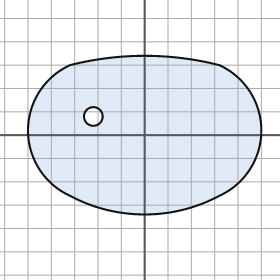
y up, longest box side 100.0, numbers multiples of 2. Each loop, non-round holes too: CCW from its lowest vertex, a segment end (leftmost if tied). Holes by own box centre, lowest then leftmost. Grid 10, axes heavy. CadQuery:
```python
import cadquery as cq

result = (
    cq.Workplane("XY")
    .moveTo(-32.0, -26.0)
    .threePointArc((0.0, -34.0), (32.0, -26.0))
    .threePointArc((50.0, 2.0), (32.0, 30.0))
    .threePointArc((0.0, 34.0), (-32.0, 30.0))
    .threePointArc((-50.0, 2.0), (-32.0, -26.0))
    .close()
    .moveTo(-22.0, 8.0)
    .circle(4.0)
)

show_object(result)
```